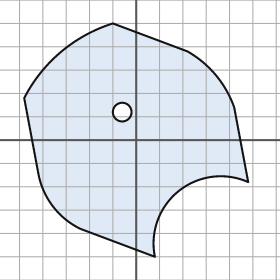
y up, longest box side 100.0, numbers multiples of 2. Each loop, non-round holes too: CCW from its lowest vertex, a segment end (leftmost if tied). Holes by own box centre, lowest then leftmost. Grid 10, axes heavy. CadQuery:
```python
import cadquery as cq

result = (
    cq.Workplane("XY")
    .moveTo(8.0, -50.0)
    .threePointArc((18.0, -22.0), (48.0, -18.0))
    .lineTo(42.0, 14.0)
    .threePointArc((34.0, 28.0), (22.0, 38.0))
    .lineTo(-10.0, 50.0)
    .threePointArc((-32.0, 38.0), (-48.0, 18.0))
    .lineTo(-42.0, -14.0)
    .threePointArc((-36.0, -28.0), (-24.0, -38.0))
    .close()
    .moveTo(-6.0, 12.0)
    .circle(4.0)
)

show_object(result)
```